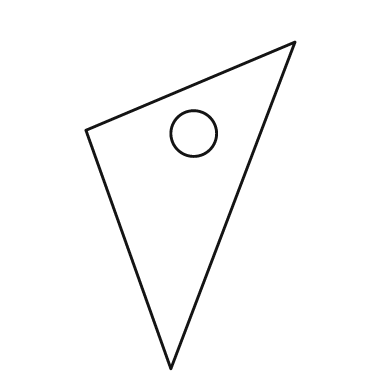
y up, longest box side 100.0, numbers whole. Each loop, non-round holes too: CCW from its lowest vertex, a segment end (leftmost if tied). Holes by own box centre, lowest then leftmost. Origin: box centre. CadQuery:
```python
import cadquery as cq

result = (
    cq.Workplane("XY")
    .moveTo(-6.0, -50.0)
    .lineTo(32.0, 50.0)
    .lineTo(-32.0, 23.0)
    .close()
    .moveTo(1.0, 22.0)
    .circle(7.0)
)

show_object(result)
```